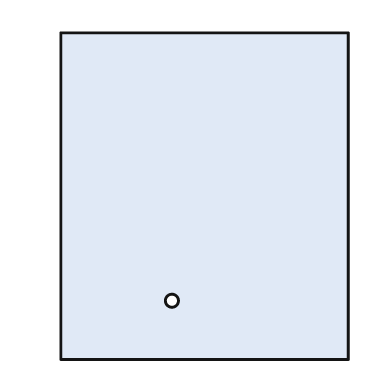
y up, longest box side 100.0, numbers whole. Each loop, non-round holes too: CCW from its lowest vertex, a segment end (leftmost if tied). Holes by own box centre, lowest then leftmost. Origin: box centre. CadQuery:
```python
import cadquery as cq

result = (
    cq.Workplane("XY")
    .moveTo(-44.0, -50.0)
    .lineTo(44.0, -50.0)
    .lineTo(44.0, 50.0)
    .lineTo(-44.0, 50.0)
    .close()
    .moveTo(-10.0, -32.0)
    .circle(2.0)
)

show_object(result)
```